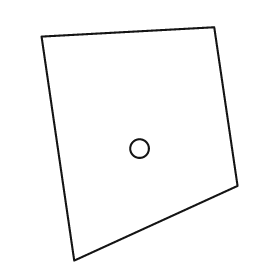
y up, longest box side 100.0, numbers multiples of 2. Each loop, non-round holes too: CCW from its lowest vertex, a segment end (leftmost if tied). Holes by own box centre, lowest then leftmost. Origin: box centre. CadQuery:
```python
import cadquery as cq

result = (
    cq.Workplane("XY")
    .moveTo(-28.0, -50.0)
    .lineTo(42.0, -18.0)
    .lineTo(32.0, 50.0)
    .lineTo(-42.0, 46.0)
    .close()
    .moveTo(0.0, -2.0)
    .circle(4.0)
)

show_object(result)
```